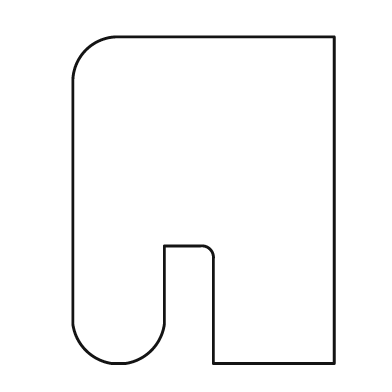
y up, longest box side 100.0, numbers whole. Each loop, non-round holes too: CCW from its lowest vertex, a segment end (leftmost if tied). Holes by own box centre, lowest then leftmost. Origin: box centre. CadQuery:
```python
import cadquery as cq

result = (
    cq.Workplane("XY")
    .moveTo(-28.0, -50.0)
    .lineTo(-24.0, -50.0)
    .threePointArc((-16.0, -46.0), (-12.0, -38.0))
    .lineTo(-12.0, -14.0)
    .lineTo(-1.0, -14.0)
    .threePointArc((2.0, -15.0), (3.0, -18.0))
    .lineTo(3.0, -50.0)
    .lineTo(40.0, -50.0)
    .lineTo(40.0, 50.0)
    .lineTo(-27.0, 50.0)
    .threePointArc((-36.0, 46.0), (-40.0, 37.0))
    .lineTo(-40.0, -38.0)
    .threePointArc((-36.0, -46.0), (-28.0, -50.0))
    .close()
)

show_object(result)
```